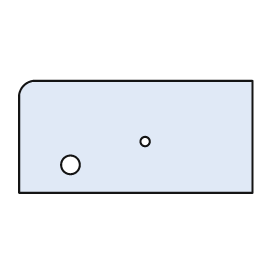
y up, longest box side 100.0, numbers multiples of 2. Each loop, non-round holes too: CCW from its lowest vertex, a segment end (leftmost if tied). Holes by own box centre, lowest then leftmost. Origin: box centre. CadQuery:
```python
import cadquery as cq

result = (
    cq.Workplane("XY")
    .moveTo(-50.0, -24.0)
    .lineTo(50.0, -24.0)
    .lineTo(50.0, 24.0)
    .lineTo(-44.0, 24.0)
    .threePointArc((-48.0, 22.0), (-50.0, 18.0))
    .close()
    .moveTo(-28.0, -12.0)
    .circle(4.0)
    .moveTo(4.0, -2.0)
    .circle(2.0)
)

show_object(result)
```